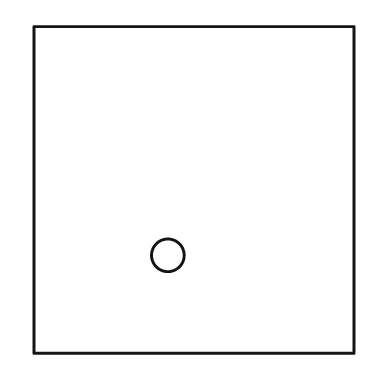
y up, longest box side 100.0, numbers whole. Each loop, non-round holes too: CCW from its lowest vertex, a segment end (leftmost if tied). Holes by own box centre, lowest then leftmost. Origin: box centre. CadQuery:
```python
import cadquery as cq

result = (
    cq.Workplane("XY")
    .moveTo(-49.0, -50.0)
    .lineTo(49.0, -50.0)
    .lineTo(49.0, 50.0)
    .lineTo(-49.0, 50.0)
    .close()
    .moveTo(-8.0, -20.0)
    .circle(5.0)
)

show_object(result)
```